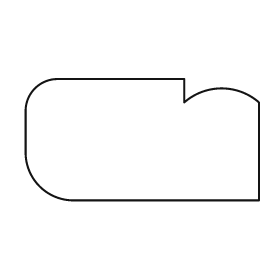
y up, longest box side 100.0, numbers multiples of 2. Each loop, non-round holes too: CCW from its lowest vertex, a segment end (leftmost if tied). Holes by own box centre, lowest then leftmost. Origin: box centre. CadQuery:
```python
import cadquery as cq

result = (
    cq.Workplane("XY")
    .moveTo(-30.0, -26.0)
    .lineTo(50.0, -26.0)
    .lineTo(50.0, 16.0)
    .threePointArc((34.0, 22.0), (18.0, 16.0))
    .lineTo(18.0, 26.0)
    .lineTo(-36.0, 26.0)
    .threePointArc((-46.0, 22.0), (-50.0, 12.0))
    .lineTo(-50.0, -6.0)
    .threePointArc((-44.0, -20.0), (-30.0, -26.0))
    .close()
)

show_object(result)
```